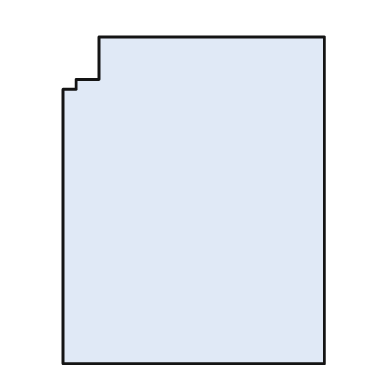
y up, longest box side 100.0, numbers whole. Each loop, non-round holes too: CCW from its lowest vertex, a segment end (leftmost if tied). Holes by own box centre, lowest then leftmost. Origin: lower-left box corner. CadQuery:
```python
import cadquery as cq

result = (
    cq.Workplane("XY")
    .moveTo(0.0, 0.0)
    .lineTo(80.0, 0.0)
    .lineTo(80.0, 100.0)
    .lineTo(11.0, 100.0)
    .lineTo(11.0, 87.0)
    .lineTo(4.0, 87.0)
    .lineTo(4.0, 84.0)
    .lineTo(0.0, 84.0)
    .close()
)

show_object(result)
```